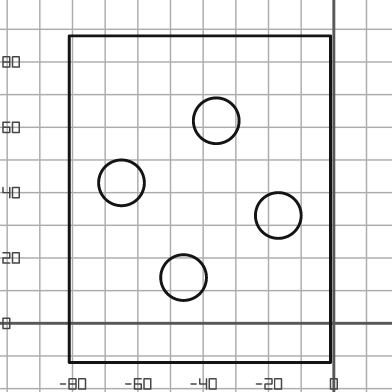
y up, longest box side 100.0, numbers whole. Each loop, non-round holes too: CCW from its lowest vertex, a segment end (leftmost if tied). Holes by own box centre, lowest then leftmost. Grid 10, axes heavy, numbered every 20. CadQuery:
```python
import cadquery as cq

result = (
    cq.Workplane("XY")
    .moveTo(-81.0, -12.0)
    .lineTo(-1.0, -12.0)
    .lineTo(-1.0, 88.0)
    .lineTo(-81.0, 88.0)
    .close()
    .moveTo(-46.0, 14.0)
    .circle(7.0)
    .moveTo(-17.0, 33.0)
    .circle(7.0)
    .moveTo(-65.0, 43.0)
    .circle(7.0)
    .moveTo(-36.0, 62.0)
    .circle(7.0)
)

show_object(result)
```